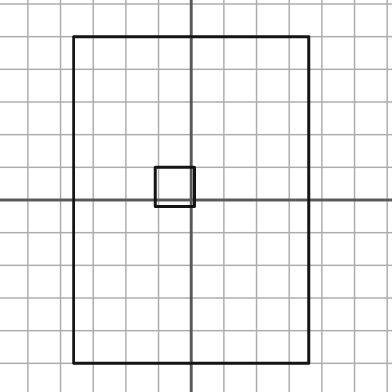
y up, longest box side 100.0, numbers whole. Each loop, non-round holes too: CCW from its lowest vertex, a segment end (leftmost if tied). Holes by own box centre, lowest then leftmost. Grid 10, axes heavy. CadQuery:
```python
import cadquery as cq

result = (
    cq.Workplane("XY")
    .moveTo(-36.0, -50.0)
    .lineTo(36.0, -50.0)
    .lineTo(36.0, 50.0)
    .lineTo(-36.0, 50.0)
    .close()
    .moveTo(-11.0, -2.0)
    .lineTo(1.0, -2.0)
    .lineTo(1.0, 10.0)
    .lineTo(-11.0, 10.0)
    .close()
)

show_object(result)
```